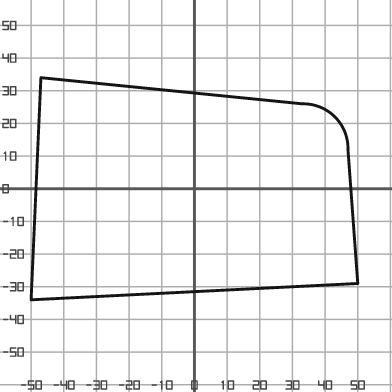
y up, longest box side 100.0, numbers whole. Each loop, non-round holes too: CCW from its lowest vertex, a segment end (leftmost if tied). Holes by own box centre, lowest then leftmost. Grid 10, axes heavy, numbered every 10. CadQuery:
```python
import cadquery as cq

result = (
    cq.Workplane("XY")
    .moveTo(-50.0, -34.0)
    .lineTo(50.0, -29.0)
    .lineTo(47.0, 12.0)
    .threePointArc((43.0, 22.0), (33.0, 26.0))
    .lineTo(-47.0, 34.0)
    .close()
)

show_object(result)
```